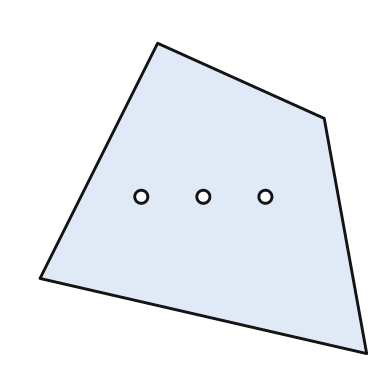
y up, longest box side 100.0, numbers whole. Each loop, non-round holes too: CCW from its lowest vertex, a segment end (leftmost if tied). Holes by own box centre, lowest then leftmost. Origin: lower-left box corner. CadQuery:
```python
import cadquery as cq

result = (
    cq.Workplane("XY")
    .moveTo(100.0, 0.0)
    .lineTo(87.0, 72.0)
    .lineTo(36.0, 95.0)
    .lineTo(0.0, 23.0)
    .close()
    .moveTo(31.0, 48.0)
    .circle(2.0)
    .moveTo(50.0, 48.0)
    .circle(2.0)
    .moveTo(69.0, 48.0)
    .circle(2.0)
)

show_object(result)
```